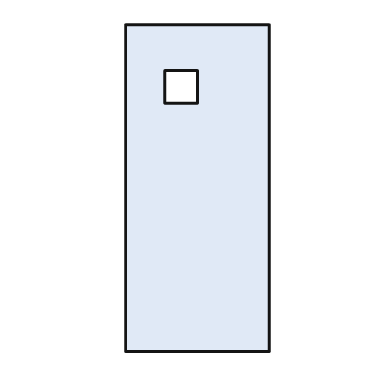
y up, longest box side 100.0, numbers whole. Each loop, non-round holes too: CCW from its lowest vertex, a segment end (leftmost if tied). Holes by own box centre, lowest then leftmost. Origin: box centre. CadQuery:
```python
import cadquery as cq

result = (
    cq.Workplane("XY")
    .moveTo(-22.0, -50.0)
    .lineTo(22.0, -50.0)
    .lineTo(22.0, 50.0)
    .lineTo(-22.0, 50.0)
    .close()
    .moveTo(-10.0, 26.0)
    .lineTo(0.0, 26.0)
    .lineTo(0.0, 36.0)
    .lineTo(-10.0, 36.0)
    .close()
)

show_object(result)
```